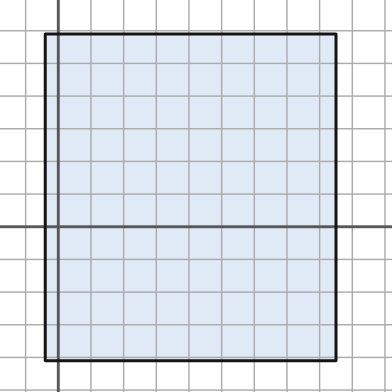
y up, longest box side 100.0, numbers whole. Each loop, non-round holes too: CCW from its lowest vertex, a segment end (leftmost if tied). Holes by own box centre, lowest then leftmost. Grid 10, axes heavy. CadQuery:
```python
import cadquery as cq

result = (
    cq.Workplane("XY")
    .moveTo(-4.0, -41.0)
    .lineTo(85.0, -41.0)
    .lineTo(85.0, 59.0)
    .lineTo(-4.0, 59.0)
    .close()
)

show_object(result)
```